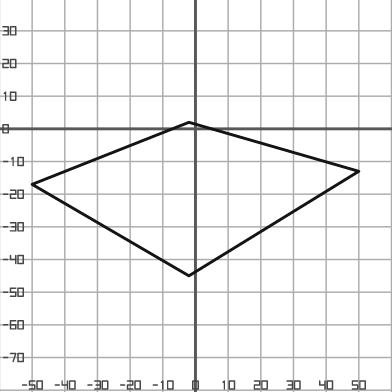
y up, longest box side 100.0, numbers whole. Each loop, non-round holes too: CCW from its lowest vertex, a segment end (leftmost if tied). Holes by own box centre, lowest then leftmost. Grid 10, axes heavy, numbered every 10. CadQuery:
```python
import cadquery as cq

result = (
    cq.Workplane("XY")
    .moveTo(-2.0, -45.0)
    .lineTo(50.0, -13.0)
    .lineTo(-2.0, 2.0)
    .lineTo(-50.0, -17.0)
    .close()
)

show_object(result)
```